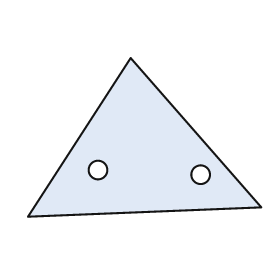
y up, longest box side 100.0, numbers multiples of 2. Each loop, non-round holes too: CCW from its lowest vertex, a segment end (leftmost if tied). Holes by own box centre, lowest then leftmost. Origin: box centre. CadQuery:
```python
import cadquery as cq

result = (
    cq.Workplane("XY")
    .moveTo(-50.0, -34.0)
    .lineTo(50.0, -30.0)
    .lineTo(-6.0, 34.0)
    .close()
    .moveTo(24.0, -16.0)
    .circle(4.0)
    .moveTo(-20.0, -14.0)
    .circle(4.0)
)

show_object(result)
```